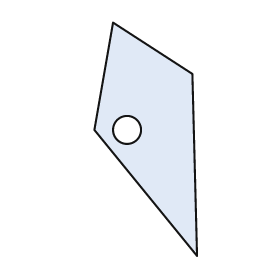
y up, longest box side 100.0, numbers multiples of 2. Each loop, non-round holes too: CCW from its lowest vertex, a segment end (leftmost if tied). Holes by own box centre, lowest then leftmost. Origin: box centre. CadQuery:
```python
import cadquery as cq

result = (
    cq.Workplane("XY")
    .moveTo(22.0, -50.0)
    .lineTo(20.0, 28.0)
    .lineTo(-14.0, 50.0)
    .lineTo(-22.0, 4.0)
    .close()
    .moveTo(-8.0, 4.0)
    .circle(6.0)
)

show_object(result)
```